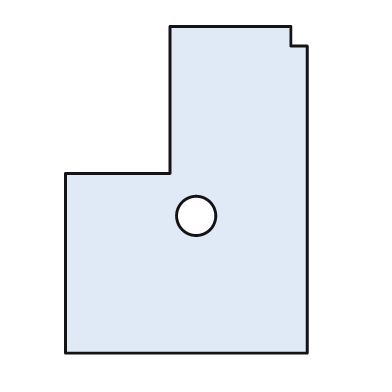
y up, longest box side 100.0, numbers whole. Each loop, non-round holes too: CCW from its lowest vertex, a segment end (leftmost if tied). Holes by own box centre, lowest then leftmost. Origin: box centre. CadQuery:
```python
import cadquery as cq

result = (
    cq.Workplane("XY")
    .moveTo(-37.0, -50.0)
    .lineTo(37.0, -50.0)
    .lineTo(37.0, 44.0)
    .lineTo(32.0, 44.0)
    .lineTo(32.0, 50.0)
    .lineTo(-5.0, 50.0)
    .lineTo(-5.0, 5.0)
    .lineTo(-37.0, 5.0)
    .close()
    .moveTo(3.0, -8.0)
    .circle(6.0)
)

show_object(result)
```